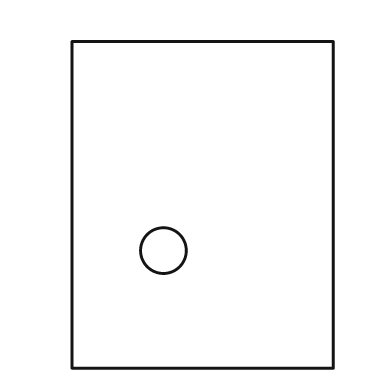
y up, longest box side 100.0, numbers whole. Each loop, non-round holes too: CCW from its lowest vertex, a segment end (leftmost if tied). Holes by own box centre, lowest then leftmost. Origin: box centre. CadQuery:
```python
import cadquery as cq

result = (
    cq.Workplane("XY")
    .moveTo(-40.0, -50.0)
    .lineTo(40.0, -50.0)
    .lineTo(40.0, 50.0)
    .lineTo(-40.0, 50.0)
    .close()
    .moveTo(-12.0, -14.0)
    .circle(7.0)
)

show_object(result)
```